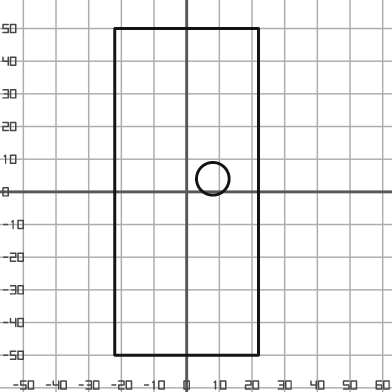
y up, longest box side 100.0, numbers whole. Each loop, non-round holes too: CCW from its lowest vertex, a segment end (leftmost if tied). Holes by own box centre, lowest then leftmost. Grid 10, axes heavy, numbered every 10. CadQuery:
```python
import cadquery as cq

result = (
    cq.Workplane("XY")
    .moveTo(-22.0, -50.0)
    .lineTo(22.0, -50.0)
    .lineTo(22.0, 50.0)
    .lineTo(-22.0, 50.0)
    .close()
    .moveTo(8.0, 4.0)
    .circle(5.0)
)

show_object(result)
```